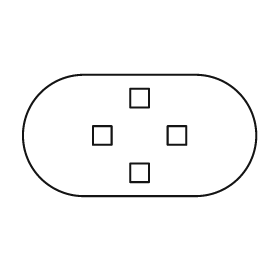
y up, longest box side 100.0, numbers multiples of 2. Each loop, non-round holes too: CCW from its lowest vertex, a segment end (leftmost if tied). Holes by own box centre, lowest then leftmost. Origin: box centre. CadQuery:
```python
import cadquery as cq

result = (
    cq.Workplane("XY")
    .moveTo(-24.0, -26.0)
    .lineTo(24.0, -26.0)
    .threePointArc((50.0, 0.0), (24.0, 26.0))
    .lineTo(-24.0, 26.0)
    .threePointArc((-50.0, 0.0), (-24.0, -26.0))
    .close()
    .moveTo(-4.0, -20.0)
    .lineTo(4.0, -20.0)
    .lineTo(4.0, -12.0)
    .lineTo(-4.0, -12.0)
    .close()
    .moveTo(-20.0, -4.0)
    .lineTo(-12.0, -4.0)
    .lineTo(-12.0, 4.0)
    .lineTo(-20.0, 4.0)
    .close()
    .moveTo(12.0, -4.0)
    .lineTo(20.0, -4.0)
    .lineTo(20.0, 4.0)
    .lineTo(12.0, 4.0)
    .close()
    .moveTo(-4.0, 12.0)
    .lineTo(4.0, 12.0)
    .lineTo(4.0, 20.0)
    .lineTo(-4.0, 20.0)
    .close()
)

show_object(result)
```